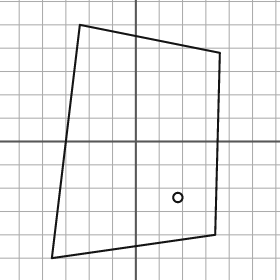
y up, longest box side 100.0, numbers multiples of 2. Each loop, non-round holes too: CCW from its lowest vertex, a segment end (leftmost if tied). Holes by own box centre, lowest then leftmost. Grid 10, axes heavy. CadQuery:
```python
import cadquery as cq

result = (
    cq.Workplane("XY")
    .moveTo(-36.0, -50.0)
    .lineTo(34.0, -40.0)
    .lineTo(36.0, 38.0)
    .lineTo(-24.0, 50.0)
    .close()
    .moveTo(18.0, -24.0)
    .circle(2.0)
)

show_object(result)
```